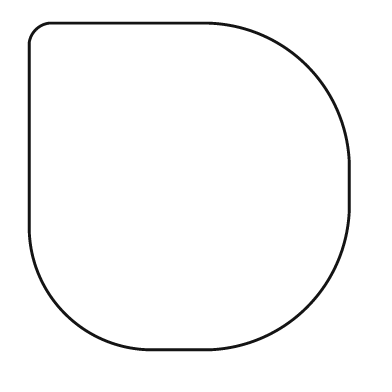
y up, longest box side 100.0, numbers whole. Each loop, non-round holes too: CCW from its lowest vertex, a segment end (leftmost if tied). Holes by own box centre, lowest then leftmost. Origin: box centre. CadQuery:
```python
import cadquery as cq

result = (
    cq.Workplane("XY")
    .moveTo(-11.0, -50.0)
    .lineTo(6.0, -50.0)
    .threePointArc((36.0, -37.0), (49.0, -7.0))
    .lineTo(49.0, 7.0)
    .threePointArc((36.0, 37.0), (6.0, 50.0))
    .lineTo(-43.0, 50.0)
    .threePointArc((-47.0, 48.0), (-49.0, 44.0))
    .lineTo(-49.0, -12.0)
    .threePointArc((-38.0, -39.0), (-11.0, -50.0))
    .close()
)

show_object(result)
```